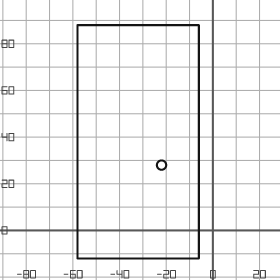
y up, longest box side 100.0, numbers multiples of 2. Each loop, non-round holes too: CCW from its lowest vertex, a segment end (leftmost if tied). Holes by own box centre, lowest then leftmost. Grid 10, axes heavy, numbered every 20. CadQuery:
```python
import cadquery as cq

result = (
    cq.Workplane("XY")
    .moveTo(-58.0, -12.0)
    .lineTo(-6.0, -12.0)
    .lineTo(-6.0, 88.0)
    .lineTo(-58.0, 88.0)
    .close()
    .moveTo(-22.0, 28.0)
    .circle(2.0)
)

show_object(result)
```